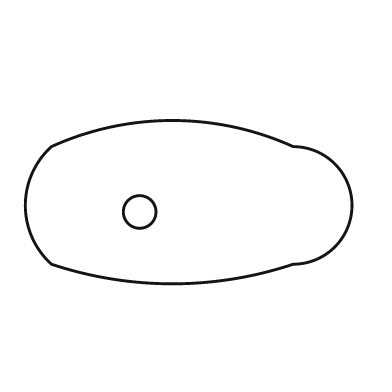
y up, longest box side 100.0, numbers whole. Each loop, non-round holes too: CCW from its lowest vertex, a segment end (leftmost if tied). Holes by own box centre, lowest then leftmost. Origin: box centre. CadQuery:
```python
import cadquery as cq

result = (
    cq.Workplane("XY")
    .moveTo(-42.0, -19.0)
    .threePointArc((-5.0, -25.0), (32.0, -19.0))
    .threePointArc((50.0, -1.0), (32.0, 17.0))
    .threePointArc((-5.0, 25.0), (-42.0, 17.0))
    .threePointArc((-50.0, -1.0), (-42.0, -19.0))
    .close()
    .moveTo(-15.0, -3.0)
    .circle(5.0)
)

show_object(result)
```